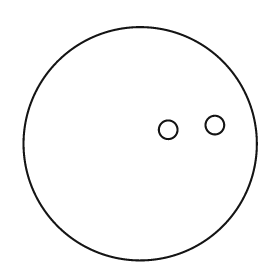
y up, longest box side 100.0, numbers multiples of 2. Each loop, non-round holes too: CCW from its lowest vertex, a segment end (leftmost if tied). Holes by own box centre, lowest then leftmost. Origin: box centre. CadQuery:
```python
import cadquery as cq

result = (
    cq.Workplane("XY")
    .moveTo(0.0, 0.0)
    .circle(50.0)
    .moveTo(12.0, 6.0)
    .circle(4.0)
    .moveTo(32.0, 8.0)
    .circle(4.0)
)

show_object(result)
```